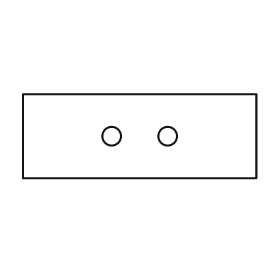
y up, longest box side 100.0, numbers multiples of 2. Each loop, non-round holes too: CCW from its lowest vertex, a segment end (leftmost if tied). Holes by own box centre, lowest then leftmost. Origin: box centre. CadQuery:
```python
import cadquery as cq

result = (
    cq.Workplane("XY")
    .moveTo(-50.0, -18.0)
    .lineTo(50.0, -18.0)
    .lineTo(50.0, 18.0)
    .lineTo(-50.0, 18.0)
    .close()
    .moveTo(-12.0, 0.0)
    .circle(4.0)
    .moveTo(12.0, 0.0)
    .circle(4.0)
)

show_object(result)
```